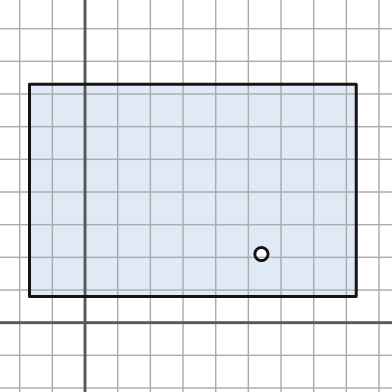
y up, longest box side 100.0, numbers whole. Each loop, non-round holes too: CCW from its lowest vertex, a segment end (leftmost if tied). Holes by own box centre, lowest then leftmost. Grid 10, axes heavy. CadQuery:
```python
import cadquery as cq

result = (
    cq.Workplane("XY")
    .moveTo(-17.0, 8.0)
    .lineTo(83.0, 8.0)
    .lineTo(83.0, 73.0)
    .lineTo(-17.0, 73.0)
    .close()
    .moveTo(54.0, 21.0)
    .circle(2.0)
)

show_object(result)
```